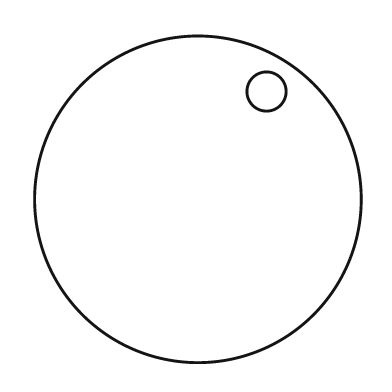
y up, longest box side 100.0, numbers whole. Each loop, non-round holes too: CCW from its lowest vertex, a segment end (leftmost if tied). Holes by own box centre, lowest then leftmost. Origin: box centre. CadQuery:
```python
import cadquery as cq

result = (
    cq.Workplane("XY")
    .moveTo(0.0, 0.0)
    .circle(50.0)
    .moveTo(21.0, 33.0)
    .circle(6.0)
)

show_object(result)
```